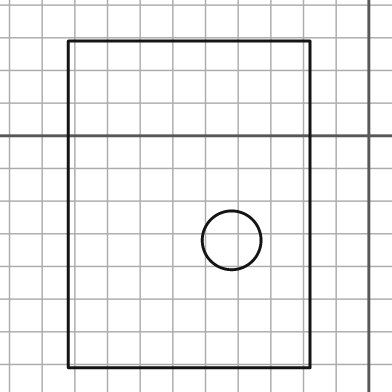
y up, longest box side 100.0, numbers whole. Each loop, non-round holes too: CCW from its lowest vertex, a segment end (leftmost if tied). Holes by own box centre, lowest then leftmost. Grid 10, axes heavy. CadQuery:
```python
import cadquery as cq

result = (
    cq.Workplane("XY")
    .moveTo(-92.0, -71.0)
    .lineTo(-18.0, -71.0)
    .lineTo(-18.0, 29.0)
    .lineTo(-92.0, 29.0)
    .close()
    .moveTo(-42.0, -32.0)
    .circle(9.0)
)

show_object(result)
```